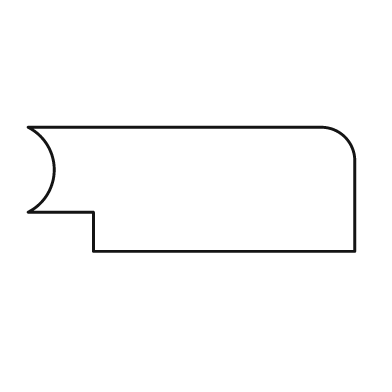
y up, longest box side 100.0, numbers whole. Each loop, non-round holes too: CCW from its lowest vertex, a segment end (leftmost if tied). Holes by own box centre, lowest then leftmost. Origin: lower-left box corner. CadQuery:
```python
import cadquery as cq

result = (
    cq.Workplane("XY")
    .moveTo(20.0, 0.0)
    .lineTo(100.0, 0.0)
    .lineTo(100.0, 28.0)
    .threePointArc((97.0, 35.0), (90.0, 38.0))
    .lineTo(0.0, 38.0)
    .threePointArc((8.0, 25.0), (0.0, 12.0))
    .lineTo(20.0, 12.0)
    .close()
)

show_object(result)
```